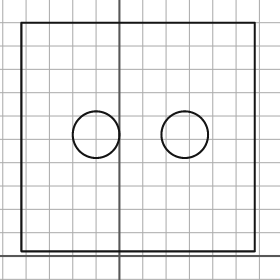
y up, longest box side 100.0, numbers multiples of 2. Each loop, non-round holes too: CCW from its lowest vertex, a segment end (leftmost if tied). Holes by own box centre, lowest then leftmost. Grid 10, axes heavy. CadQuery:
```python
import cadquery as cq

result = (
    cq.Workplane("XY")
    .moveTo(-42.0, 2.0)
    .lineTo(58.0, 2.0)
    .lineTo(58.0, 100.0)
    .lineTo(-42.0, 100.0)
    .close()
    .moveTo(-10.0, 52.0)
    .circle(10.0)
    .moveTo(28.0, 52.0)
    .circle(10.0)
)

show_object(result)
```